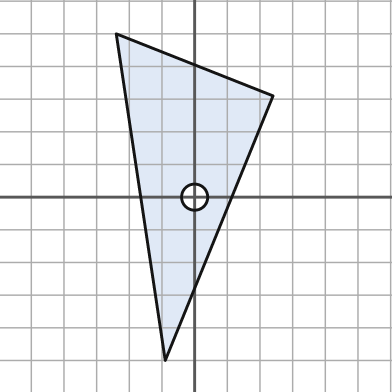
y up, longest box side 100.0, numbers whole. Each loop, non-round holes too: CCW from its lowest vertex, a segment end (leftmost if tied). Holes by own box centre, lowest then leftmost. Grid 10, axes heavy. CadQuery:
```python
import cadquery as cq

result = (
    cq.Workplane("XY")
    .moveTo(-9.0, -50.0)
    .lineTo(24.0, 31.0)
    .lineTo(-24.0, 50.0)
    .close()
    .moveTo(0.0, 0.0)
    .circle(4.0)
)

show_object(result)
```